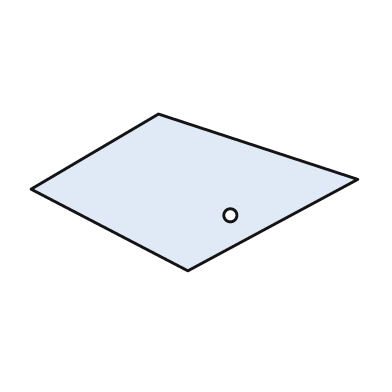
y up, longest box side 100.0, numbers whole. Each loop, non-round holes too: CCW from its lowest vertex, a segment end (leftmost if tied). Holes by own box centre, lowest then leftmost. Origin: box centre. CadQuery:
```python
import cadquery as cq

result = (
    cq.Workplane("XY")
    .moveTo(-2.0, -24.0)
    .lineTo(50.0, 4.0)
    .lineTo(-11.0, 24.0)
    .lineTo(-50.0, 1.0)
    .close()
    .moveTo(11.0, -7.0)
    .circle(2.0)
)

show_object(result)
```